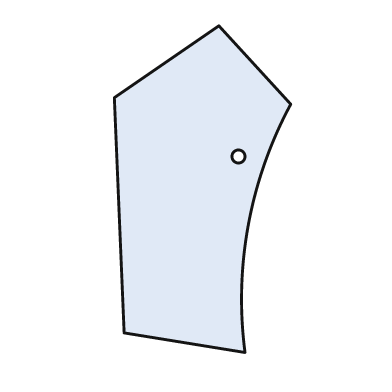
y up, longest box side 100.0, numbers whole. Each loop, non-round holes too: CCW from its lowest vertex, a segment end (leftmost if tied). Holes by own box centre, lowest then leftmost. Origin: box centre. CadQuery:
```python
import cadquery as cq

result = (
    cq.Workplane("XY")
    .moveTo(13.0, -50.0)
    .threePointArc((14.0, -11.0), (27.0, 26.0))
    .lineTo(5.0, 50.0)
    .lineTo(-27.0, 28.0)
    .lineTo(-24.0, -44.0)
    .close()
    .moveTo(11.0, 10.0)
    .circle(2.0)
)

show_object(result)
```